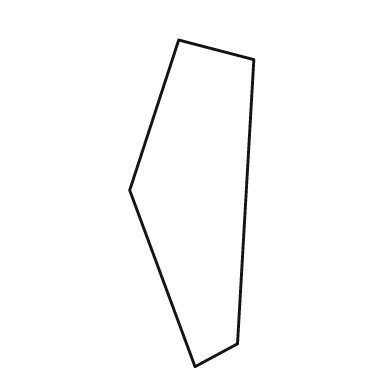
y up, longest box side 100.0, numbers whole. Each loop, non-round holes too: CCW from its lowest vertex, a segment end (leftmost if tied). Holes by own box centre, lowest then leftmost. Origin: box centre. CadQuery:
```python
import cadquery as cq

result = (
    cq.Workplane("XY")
    .moveTo(1.0, -50.0)
    .lineTo(14.0, -43.0)
    .lineTo(19.0, 44.0)
    .lineTo(-4.0, 50.0)
    .lineTo(-19.0, 4.0)
    .close()
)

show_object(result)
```